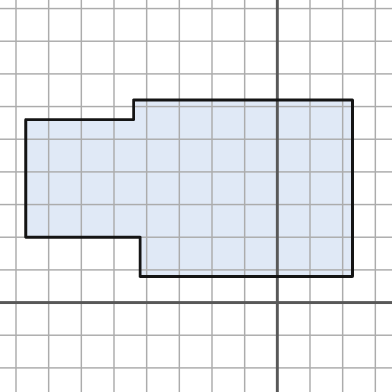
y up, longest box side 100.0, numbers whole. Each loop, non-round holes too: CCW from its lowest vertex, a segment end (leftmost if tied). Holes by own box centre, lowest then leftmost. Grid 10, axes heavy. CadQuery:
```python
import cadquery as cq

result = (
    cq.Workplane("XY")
    .moveTo(-42.0, 8.0)
    .lineTo(23.0, 8.0)
    .lineTo(23.0, 62.0)
    .lineTo(-44.0, 62.0)
    .lineTo(-44.0, 56.0)
    .lineTo(-77.0, 56.0)
    .lineTo(-77.0, 20.0)
    .lineTo(-42.0, 20.0)
    .close()
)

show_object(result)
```